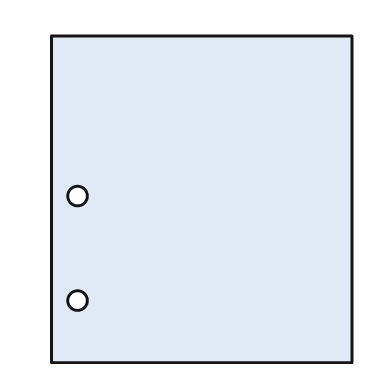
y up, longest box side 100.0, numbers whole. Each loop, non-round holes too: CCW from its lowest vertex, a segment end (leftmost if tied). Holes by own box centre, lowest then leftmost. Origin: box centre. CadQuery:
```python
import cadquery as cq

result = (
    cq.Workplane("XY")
    .moveTo(-46.0, -50.0)
    .lineTo(46.0, -50.0)
    .lineTo(46.0, 50.0)
    .lineTo(-46.0, 50.0)
    .close()
    .moveTo(-38.0, -31.0)
    .circle(3.0)
    .moveTo(-38.0, 1.0)
    .circle(3.0)
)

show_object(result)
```